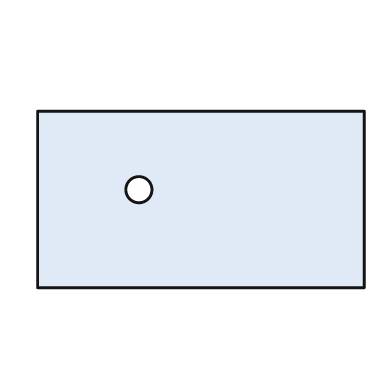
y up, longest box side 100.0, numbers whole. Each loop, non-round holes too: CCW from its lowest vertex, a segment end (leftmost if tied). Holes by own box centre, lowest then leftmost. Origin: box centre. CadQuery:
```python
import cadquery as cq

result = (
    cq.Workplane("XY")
    .moveTo(-50.0, -27.0)
    .lineTo(50.0, -27.0)
    .lineTo(50.0, 27.0)
    .lineTo(-50.0, 27.0)
    .close()
    .moveTo(-19.0, 3.0)
    .circle(4.0)
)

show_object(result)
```